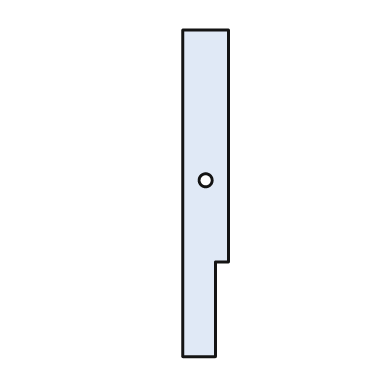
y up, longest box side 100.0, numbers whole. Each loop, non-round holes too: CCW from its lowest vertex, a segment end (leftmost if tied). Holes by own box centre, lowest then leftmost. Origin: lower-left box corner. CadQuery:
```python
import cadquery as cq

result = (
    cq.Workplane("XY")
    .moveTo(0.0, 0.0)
    .lineTo(10.0, 0.0)
    .lineTo(10.0, 29.0)
    .lineTo(14.0, 29.0)
    .lineTo(14.0, 100.0)
    .lineTo(0.0, 100.0)
    .close()
    .moveTo(7.0, 54.0)
    .circle(2.0)
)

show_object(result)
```